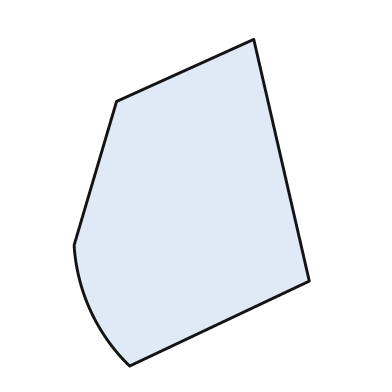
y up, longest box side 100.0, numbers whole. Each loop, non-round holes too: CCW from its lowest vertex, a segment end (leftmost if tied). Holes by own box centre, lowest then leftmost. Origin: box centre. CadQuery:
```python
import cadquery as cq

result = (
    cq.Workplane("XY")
    .moveTo(-19.0, -50.0)
    .lineTo(36.0, -24.0)
    .lineTo(19.0, 50.0)
    .lineTo(-23.0, 31.0)
    .lineTo(-36.0, -13.0)
    .threePointArc((-31.0, -33.0), (-19.0, -50.0))
    .close()
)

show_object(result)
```